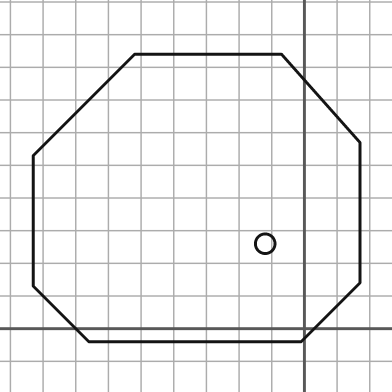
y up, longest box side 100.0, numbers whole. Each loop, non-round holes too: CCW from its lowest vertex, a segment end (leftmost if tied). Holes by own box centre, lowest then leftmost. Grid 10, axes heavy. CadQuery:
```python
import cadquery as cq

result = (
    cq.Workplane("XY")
    .moveTo(-66.0, -4.0)
    .lineTo(-1.0, -4.0)
    .lineTo(17.0, 14.0)
    .lineTo(17.0, 57.0)
    .lineTo(-7.0, 84.0)
    .lineTo(-52.0, 84.0)
    .lineTo(-83.0, 53.0)
    .lineTo(-83.0, 13.0)
    .close()
    .moveTo(-12.0, 26.0)
    .circle(3.0)
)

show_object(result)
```